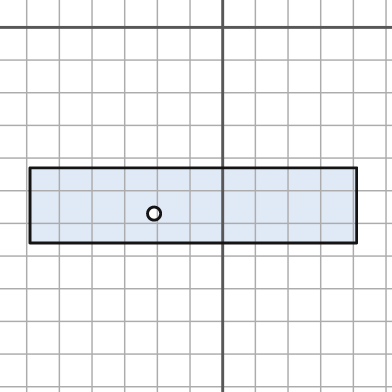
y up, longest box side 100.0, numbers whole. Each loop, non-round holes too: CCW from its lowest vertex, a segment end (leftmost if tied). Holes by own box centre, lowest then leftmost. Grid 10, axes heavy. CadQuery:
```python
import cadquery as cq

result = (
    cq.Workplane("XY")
    .moveTo(-59.0, -66.0)
    .lineTo(41.0, -66.0)
    .lineTo(41.0, -43.0)
    .lineTo(-59.0, -43.0)
    .close()
    .moveTo(-21.0, -57.0)
    .circle(2.0)
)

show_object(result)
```